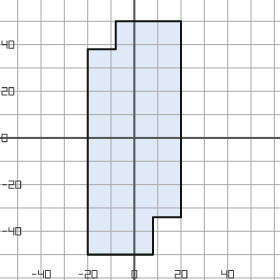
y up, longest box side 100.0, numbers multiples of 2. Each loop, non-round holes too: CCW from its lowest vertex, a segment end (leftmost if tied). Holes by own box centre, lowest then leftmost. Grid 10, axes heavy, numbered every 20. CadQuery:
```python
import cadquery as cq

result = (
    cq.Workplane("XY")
    .moveTo(-20.0, -50.0)
    .lineTo(8.0, -50.0)
    .lineTo(8.0, -34.0)
    .lineTo(20.0, -34.0)
    .lineTo(20.0, 50.0)
    .lineTo(-8.0, 50.0)
    .lineTo(-8.0, 38.0)
    .lineTo(-20.0, 38.0)
    .close()
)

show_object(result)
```